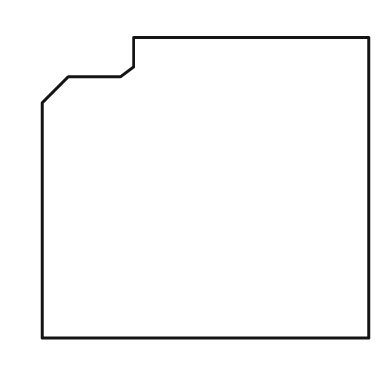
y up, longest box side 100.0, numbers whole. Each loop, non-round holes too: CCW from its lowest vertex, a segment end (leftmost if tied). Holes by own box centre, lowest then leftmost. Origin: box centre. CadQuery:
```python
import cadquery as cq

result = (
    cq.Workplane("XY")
    .moveTo(-50.0, -46.0)
    .lineTo(50.0, -46.0)
    .lineTo(50.0, 46.0)
    .lineTo(-22.0, 46.0)
    .lineTo(-22.0, 37.0)
    .lineTo(-26.0, 34.0)
    .lineTo(-42.0, 34.0)
    .lineTo(-50.0, 26.0)
    .close()
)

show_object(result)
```